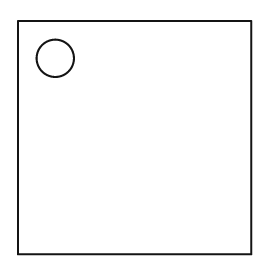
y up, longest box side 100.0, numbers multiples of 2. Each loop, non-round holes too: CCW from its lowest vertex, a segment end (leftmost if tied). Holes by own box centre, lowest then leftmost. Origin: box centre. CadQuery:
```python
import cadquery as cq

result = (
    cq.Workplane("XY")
    .moveTo(-50.0, -50.0)
    .lineTo(50.0, -50.0)
    .lineTo(50.0, 50.0)
    .lineTo(-50.0, 50.0)
    .close()
    .moveTo(-34.0, 34.0)
    .circle(8.0)
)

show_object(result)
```